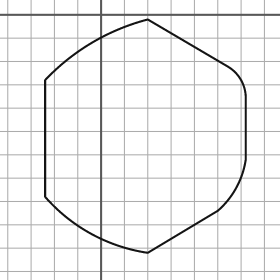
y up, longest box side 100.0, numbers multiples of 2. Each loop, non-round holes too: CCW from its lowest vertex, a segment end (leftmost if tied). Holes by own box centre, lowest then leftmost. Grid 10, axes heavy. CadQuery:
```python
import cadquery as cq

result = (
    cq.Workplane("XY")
    .moveTo(20.0, -102.0)
    .lineTo(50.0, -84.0)
    .threePointArc((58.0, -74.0), (62.0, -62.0))
    .lineTo(62.0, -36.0)
    .threePointArc((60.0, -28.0), (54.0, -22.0))
    .lineTo(20.0, -2.0)
    .threePointArc((-4.0, -12.0), (-24.0, -28.0))
    .lineTo(-24.0, -78.0)
    .threePointArc((-4.0, -94.0), (20.0, -102.0))
    .close()
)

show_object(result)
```